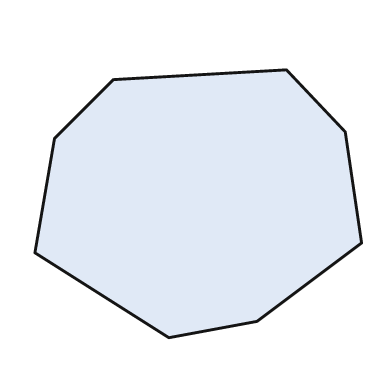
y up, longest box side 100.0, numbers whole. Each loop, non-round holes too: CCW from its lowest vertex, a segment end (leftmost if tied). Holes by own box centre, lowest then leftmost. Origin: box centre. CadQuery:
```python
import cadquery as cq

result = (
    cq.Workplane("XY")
    .moveTo(-9.0, -41.0)
    .lineTo(18.0, -36.0)
    .lineTo(50.0, -12.0)
    .lineTo(45.0, 22.0)
    .lineTo(27.0, 41.0)
    .lineTo(-26.0, 38.0)
    .lineTo(-44.0, 20.0)
    .lineTo(-50.0, -15.0)
    .close()
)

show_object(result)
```